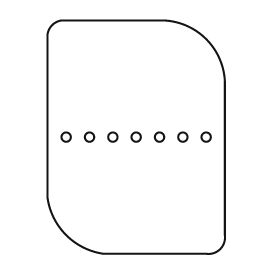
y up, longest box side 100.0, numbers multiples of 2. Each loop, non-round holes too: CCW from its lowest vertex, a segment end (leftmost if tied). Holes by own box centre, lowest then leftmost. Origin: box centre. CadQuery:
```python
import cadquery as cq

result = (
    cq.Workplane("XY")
    .moveTo(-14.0, -50.0)
    .lineTo(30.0, -50.0)
    .threePointArc((36.0, -48.0), (38.0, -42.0))
    .lineTo(38.0, 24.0)
    .threePointArc((30.0, 42.0), (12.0, 50.0))
    .lineTo(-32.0, 50.0)
    .threePointArc((-36.0, 48.0), (-38.0, 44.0))
    .lineTo(-38.0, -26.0)
    .threePointArc((-30.0, -42.0), (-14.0, -50.0))
    .close()
    .moveTo(-30.0, 0.0)
    .circle(2.0)
    .moveTo(-20.0, 0.0)
    .circle(2.0)
    .moveTo(-10.0, 0.0)
    .circle(2.0)
    .moveTo(0.0, 0.0)
    .circle(2.0)
    .moveTo(10.0, 0.0)
    .circle(2.0)
    .moveTo(20.0, 0.0)
    .circle(2.0)
    .moveTo(30.0, 0.0)
    .circle(2.0)
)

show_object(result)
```